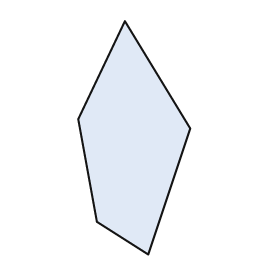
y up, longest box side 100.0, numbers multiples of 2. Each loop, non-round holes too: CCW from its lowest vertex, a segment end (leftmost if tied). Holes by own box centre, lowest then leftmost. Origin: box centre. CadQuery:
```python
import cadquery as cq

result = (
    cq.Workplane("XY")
    .moveTo(6.0, -50.0)
    .lineTo(24.0, 4.0)
    .lineTo(-4.0, 50.0)
    .lineTo(-24.0, 8.0)
    .lineTo(-16.0, -36.0)
    .close()
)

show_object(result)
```